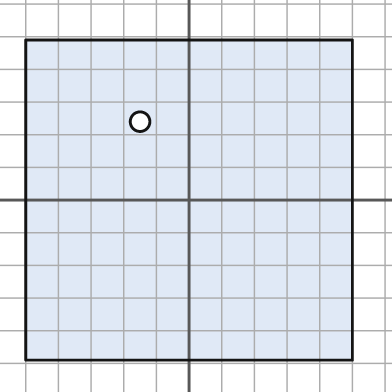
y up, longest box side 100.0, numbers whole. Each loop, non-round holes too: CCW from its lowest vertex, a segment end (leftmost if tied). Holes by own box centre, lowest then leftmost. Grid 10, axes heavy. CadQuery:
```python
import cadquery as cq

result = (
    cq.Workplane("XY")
    .moveTo(-50.0, -49.0)
    .lineTo(50.0, -49.0)
    .lineTo(50.0, 49.0)
    .lineTo(-50.0, 49.0)
    .close()
    .moveTo(-15.0, 24.0)
    .circle(3.0)
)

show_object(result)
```